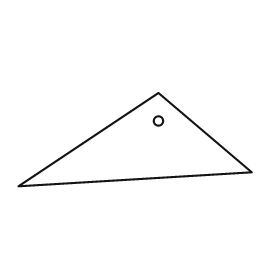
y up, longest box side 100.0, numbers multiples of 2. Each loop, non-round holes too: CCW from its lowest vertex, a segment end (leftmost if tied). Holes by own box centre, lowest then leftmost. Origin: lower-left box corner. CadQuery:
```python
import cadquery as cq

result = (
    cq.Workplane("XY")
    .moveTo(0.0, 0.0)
    .lineTo(100.0, 6.0)
    .lineTo(60.0, 40.0)
    .close()
    .moveTo(60.0, 28.0)
    .circle(2.0)
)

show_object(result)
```